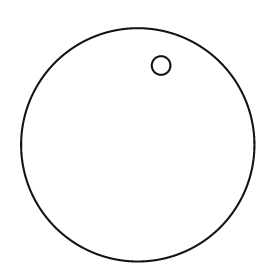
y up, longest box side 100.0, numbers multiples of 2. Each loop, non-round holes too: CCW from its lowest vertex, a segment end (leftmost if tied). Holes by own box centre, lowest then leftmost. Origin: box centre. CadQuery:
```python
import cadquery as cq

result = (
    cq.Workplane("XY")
    .moveTo(0.0, 0.0)
    .circle(50.0)
    .moveTo(10.0, 34.0)
    .circle(4.0)
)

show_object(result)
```